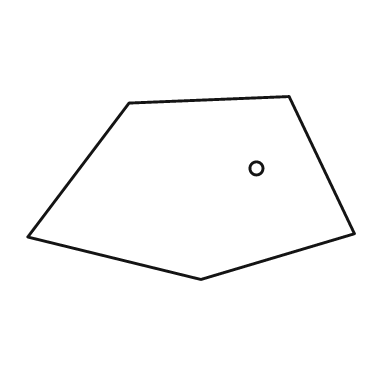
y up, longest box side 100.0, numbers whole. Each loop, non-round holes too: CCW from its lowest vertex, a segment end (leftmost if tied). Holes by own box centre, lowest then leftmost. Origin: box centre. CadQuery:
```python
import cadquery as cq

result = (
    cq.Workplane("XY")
    .moveTo(3.0, -28.0)
    .lineTo(50.0, -14.0)
    .lineTo(30.0, 28.0)
    .lineTo(-19.0, 26.0)
    .lineTo(-50.0, -15.0)
    .close()
    .moveTo(20.0, 6.0)
    .circle(2.0)
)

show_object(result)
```